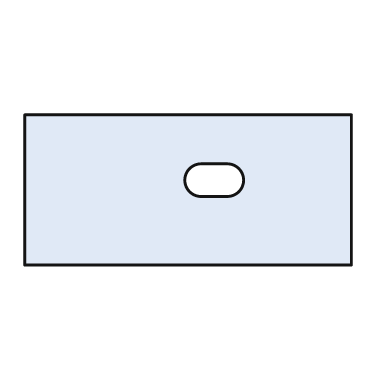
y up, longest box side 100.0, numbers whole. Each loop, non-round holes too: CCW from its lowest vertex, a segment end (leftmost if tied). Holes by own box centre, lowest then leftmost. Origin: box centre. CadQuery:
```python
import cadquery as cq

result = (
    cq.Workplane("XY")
    .moveTo(-50.0, -23.0)
    .lineTo(50.0, -23.0)
    .lineTo(50.0, 23.0)
    .lineTo(-50.0, 23.0)
    .close()
    .moveTo(4.0, -2.0)
    .lineTo(12.0, -2.0)
    .threePointArc((17.0, 3.0), (12.0, 8.0))
    .lineTo(4.0, 8.0)
    .threePointArc((-1.0, 3.0), (4.0, -2.0))
    .close()
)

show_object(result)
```